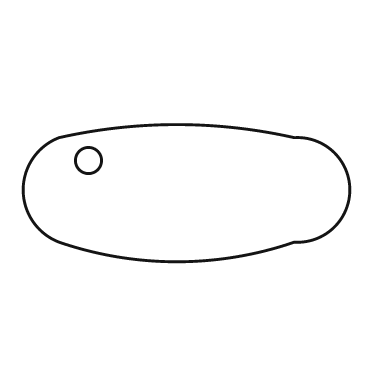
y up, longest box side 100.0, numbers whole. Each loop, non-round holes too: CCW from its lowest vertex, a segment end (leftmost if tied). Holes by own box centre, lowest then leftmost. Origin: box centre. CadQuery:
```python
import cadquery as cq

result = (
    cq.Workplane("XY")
    .moveTo(-39.0, -15.0)
    .threePointArc((-3.0, -21.0), (33.0, -15.0))
    .threePointArc((50.0, 1.0), (33.0, 17.0))
    .threePointArc((-3.0, 21.0), (-39.0, 17.0))
    .threePointArc((-50.0, 1.0), (-39.0, -15.0))
    .close()
    .moveTo(-30.0, 10.0)
    .circle(4.0)
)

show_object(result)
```